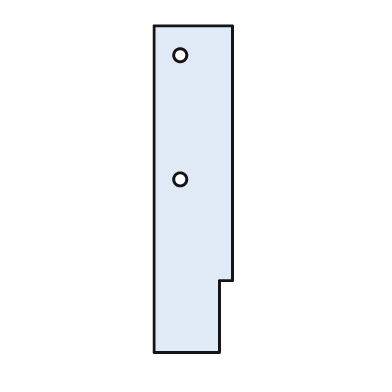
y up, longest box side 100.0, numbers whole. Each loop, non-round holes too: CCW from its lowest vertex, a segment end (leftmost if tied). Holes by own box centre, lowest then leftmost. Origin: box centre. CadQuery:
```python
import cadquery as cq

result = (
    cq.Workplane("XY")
    .moveTo(-12.0, -50.0)
    .lineTo(8.0, -50.0)
    .lineTo(8.0, -28.0)
    .lineTo(12.0, -28.0)
    .lineTo(12.0, 50.0)
    .lineTo(-12.0, 50.0)
    .close()
    .moveTo(-4.0, 3.0)
    .circle(2.0)
    .moveTo(-4.0, 41.0)
    .circle(2.0)
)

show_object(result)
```